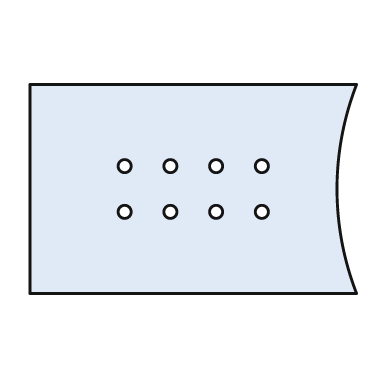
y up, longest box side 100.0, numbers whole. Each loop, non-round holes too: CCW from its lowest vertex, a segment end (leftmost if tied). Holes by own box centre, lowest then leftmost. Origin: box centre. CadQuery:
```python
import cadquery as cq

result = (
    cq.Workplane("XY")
    .moveTo(-50.0, -32.0)
    .lineTo(50.0, -32.0)
    .threePointArc((44.0, 0.0), (50.0, 32.0))
    .lineTo(-50.0, 32.0)
    .close()
    .moveTo(-21.0, -7.0)
    .circle(2.0)
    .moveTo(-7.0, -7.0)
    .circle(2.0)
    .moveTo(7.0, -7.0)
    .circle(2.0)
    .moveTo(21.0, -7.0)
    .circle(2.0)
    .moveTo(-21.0, 7.0)
    .circle(2.0)
    .moveTo(-7.0, 7.0)
    .circle(2.0)
    .moveTo(7.0, 7.0)
    .circle(2.0)
    .moveTo(21.0, 7.0)
    .circle(2.0)
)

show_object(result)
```